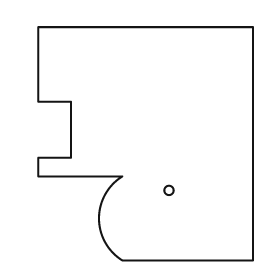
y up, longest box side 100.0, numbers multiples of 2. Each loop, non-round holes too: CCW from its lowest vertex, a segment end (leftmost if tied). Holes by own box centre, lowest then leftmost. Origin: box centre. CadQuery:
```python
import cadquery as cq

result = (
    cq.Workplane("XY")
    .moveTo(-10.0, -50.0)
    .lineTo(46.0, -50.0)
    .lineTo(46.0, 50.0)
    .lineTo(-46.0, 50.0)
    .lineTo(-46.0, 18.0)
    .lineTo(-32.0, 18.0)
    .lineTo(-32.0, -6.0)
    .lineTo(-46.0, -6.0)
    .lineTo(-46.0, -14.0)
    .lineTo(-10.0, -14.0)
    .threePointArc((-20.0, -32.0), (-10.0, -50.0))
    .close()
    .moveTo(10.0, -20.0)
    .circle(2.0)
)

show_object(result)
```